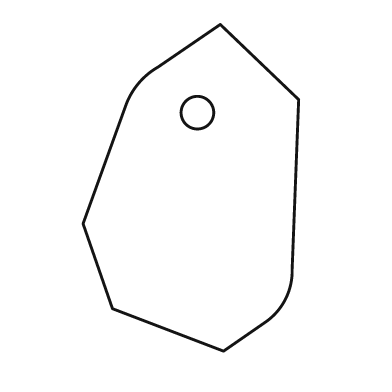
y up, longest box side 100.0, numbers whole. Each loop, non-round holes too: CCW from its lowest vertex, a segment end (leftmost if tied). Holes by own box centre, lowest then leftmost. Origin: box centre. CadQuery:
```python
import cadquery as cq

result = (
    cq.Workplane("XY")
    .moveTo(10.0, -50.0)
    .lineTo(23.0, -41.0)
    .threePointArc((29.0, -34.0), (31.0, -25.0))
    .lineTo(33.0, 27.0)
    .lineTo(9.0, 50.0)
    .lineTo(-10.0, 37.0)
    .threePointArc((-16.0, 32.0), (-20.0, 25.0))
    .lineTo(-33.0, -11.0)
    .lineTo(-24.0, -37.0)
    .close()
    .moveTo(2.0, 23.0)
    .circle(5.0)
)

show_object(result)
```